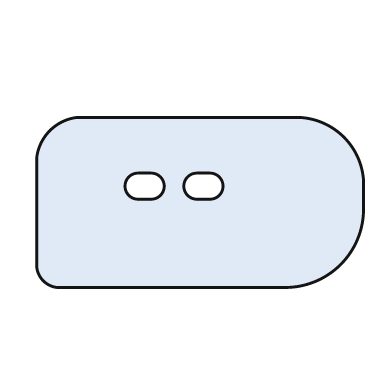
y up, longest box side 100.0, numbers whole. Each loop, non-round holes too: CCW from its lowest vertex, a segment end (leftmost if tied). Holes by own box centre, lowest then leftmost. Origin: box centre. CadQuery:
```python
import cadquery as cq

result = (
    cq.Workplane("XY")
    .moveTo(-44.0, -26.0)
    .lineTo(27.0, -26.0)
    .threePointArc((43.0, -19.0), (50.0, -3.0))
    .lineTo(50.0, 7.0)
    .threePointArc((44.0, 20.0), (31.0, 26.0))
    .lineTo(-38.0, 26.0)
    .threePointArc((-46.0, 22.0), (-50.0, 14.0))
    .lineTo(-50.0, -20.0)
    .threePointArc((-48.0, -24.0), (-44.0, -26.0))
    .close()
    .moveTo(-19.0, 1.0)
    .lineTo(-15.0, 1.0)
    .threePointArc((-11.0, 5.0), (-15.0, 9.0))
    .lineTo(-19.0, 9.0)
    .threePointArc((-23.0, 5.0), (-19.0, 1.0))
    .close()
    .moveTo(-1.0, 1.0)
    .lineTo(3.0, 1.0)
    .threePointArc((7.0, 5.0), (3.0, 9.0))
    .lineTo(-1.0, 9.0)
    .threePointArc((-5.0, 5.0), (-1.0, 1.0))
    .close()
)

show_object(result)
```